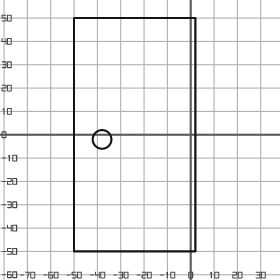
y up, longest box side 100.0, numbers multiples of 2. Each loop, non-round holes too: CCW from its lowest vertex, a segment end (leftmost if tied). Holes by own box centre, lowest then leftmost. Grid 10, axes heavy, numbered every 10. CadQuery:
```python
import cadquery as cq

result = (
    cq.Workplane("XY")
    .moveTo(-50.0, -50.0)
    .lineTo(2.0, -50.0)
    .lineTo(2.0, 50.0)
    .lineTo(-50.0, 50.0)
    .close()
    .moveTo(-38.0, -2.0)
    .circle(4.0)
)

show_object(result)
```